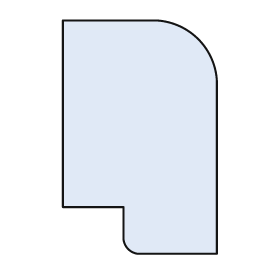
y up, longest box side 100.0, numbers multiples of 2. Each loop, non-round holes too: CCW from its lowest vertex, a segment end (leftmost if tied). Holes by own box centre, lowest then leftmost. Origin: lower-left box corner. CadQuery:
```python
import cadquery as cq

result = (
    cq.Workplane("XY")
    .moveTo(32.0, 0.0)
    .lineTo(66.0, 0.0)
    .lineTo(66.0, 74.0)
    .threePointArc((58.0, 92.0), (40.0, 100.0))
    .lineTo(0.0, 100.0)
    .lineTo(0.0, 20.0)
    .lineTo(26.0, 20.0)
    .lineTo(26.0, 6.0)
    .threePointArc((28.0, 2.0), (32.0, 0.0))
    .close()
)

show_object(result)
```